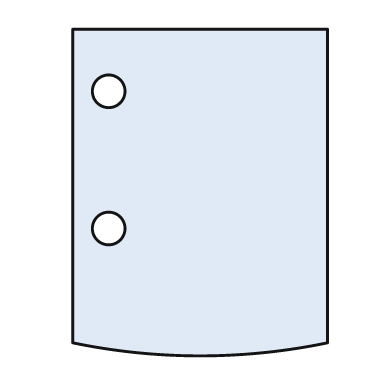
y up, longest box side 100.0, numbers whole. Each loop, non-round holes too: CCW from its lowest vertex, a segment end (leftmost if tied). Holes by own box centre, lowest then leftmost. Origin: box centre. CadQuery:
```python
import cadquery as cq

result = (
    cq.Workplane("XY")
    .moveTo(-39.0, -46.0)
    .threePointArc((0.0, -50.0), (39.0, -46.0))
    .lineTo(39.0, 50.0)
    .lineTo(-39.0, 50.0)
    .close()
    .moveTo(-28.0, -11.0)
    .circle(5.0)
    .moveTo(-28.0, 31.0)
    .circle(5.0)
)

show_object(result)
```